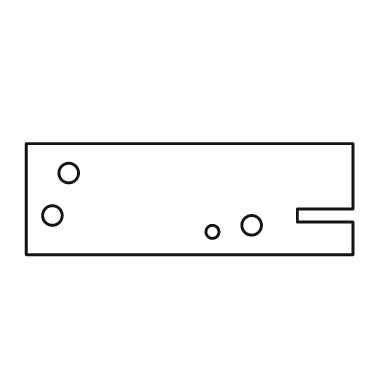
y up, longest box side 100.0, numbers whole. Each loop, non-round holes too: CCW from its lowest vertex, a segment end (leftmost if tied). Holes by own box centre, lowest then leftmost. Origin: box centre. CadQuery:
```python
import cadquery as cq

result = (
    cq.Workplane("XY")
    .moveTo(-50.0, -17.0)
    .lineTo(50.0, -17.0)
    .lineTo(50.0, -7.0)
    .lineTo(33.0, -7.0)
    .lineTo(33.0, -3.0)
    .lineTo(50.0, -3.0)
    .lineTo(50.0, 17.0)
    .lineTo(-50.0, 17.0)
    .close()
    .moveTo(7.0, -10.0)
    .circle(2.0)
    .moveTo(19.0, -8.0)
    .circle(3.0)
    .moveTo(-42.0, -5.0)
    .circle(3.0)
    .moveTo(-37.0, 8.0)
    .circle(3.0)
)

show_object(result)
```